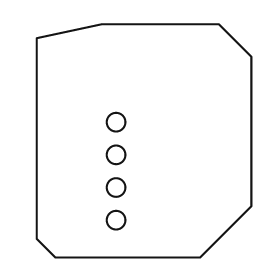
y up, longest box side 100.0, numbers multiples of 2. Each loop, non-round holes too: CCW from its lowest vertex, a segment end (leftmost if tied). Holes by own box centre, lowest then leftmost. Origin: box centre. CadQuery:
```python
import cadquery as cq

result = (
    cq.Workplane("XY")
    .moveTo(-38.0, -50.0)
    .lineTo(24.0, -50.0)
    .lineTo(46.0, -28.0)
    .lineTo(46.0, 36.0)
    .lineTo(32.0, 50.0)
    .lineTo(-18.0, 50.0)
    .lineTo(-46.0, 44.0)
    .lineTo(-46.0, -42.0)
    .close()
    .moveTo(-12.0, -34.0)
    .circle(4.0)
    .moveTo(-12.0, -20.0)
    .circle(4.0)
    .moveTo(-12.0, -6.0)
    .circle(4.0)
    .moveTo(-12.0, 8.0)
    .circle(4.0)
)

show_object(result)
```